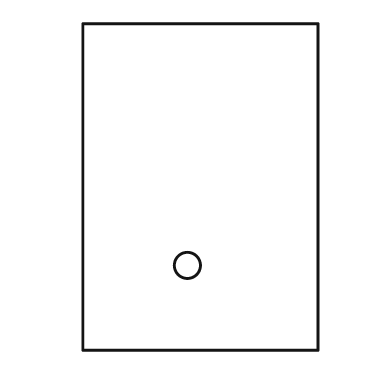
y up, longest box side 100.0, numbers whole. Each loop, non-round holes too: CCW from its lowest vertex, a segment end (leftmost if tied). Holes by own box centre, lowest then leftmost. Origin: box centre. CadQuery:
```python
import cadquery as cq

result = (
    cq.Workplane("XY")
    .moveTo(-36.0, -50.0)
    .lineTo(36.0, -50.0)
    .lineTo(36.0, 50.0)
    .lineTo(-36.0, 50.0)
    .close()
    .moveTo(-4.0, -24.0)
    .circle(4.0)
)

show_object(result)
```